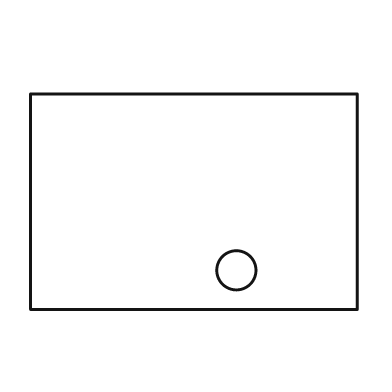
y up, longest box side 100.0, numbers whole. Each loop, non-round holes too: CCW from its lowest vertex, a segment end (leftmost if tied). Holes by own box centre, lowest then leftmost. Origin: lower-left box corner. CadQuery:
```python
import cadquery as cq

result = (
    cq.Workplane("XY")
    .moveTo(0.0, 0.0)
    .lineTo(100.0, 0.0)
    .lineTo(100.0, 66.0)
    .lineTo(0.0, 66.0)
    .close()
    .moveTo(63.0, 12.0)
    .circle(6.0)
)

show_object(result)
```